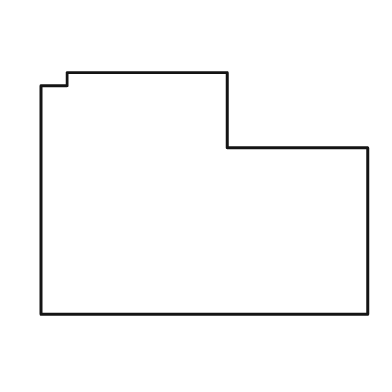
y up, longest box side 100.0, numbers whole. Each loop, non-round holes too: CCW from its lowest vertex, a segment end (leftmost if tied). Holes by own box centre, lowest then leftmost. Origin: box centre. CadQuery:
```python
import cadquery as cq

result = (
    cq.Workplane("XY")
    .moveTo(-50.0, -37.0)
    .lineTo(50.0, -37.0)
    .lineTo(50.0, 14.0)
    .lineTo(7.0, 14.0)
    .lineTo(7.0, 37.0)
    .lineTo(-42.0, 37.0)
    .lineTo(-42.0, 33.0)
    .lineTo(-50.0, 33.0)
    .close()
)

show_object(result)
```